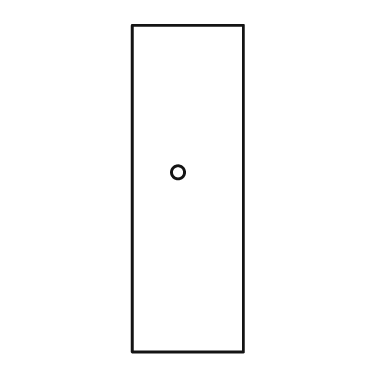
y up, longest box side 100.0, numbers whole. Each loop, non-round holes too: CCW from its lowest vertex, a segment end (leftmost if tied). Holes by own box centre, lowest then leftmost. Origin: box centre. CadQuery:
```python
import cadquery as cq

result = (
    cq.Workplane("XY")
    .moveTo(-17.0, -50.0)
    .lineTo(17.0, -50.0)
    .lineTo(17.0, 50.0)
    .lineTo(-17.0, 50.0)
    .close()
    .moveTo(-3.0, 5.0)
    .circle(2.0)
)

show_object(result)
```